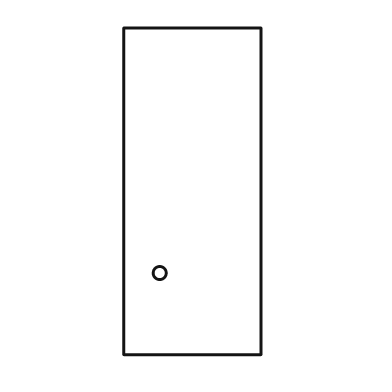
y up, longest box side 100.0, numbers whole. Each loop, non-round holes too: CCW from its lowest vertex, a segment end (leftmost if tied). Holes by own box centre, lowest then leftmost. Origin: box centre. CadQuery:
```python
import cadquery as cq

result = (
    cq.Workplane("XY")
    .moveTo(-21.0, -50.0)
    .lineTo(21.0, -50.0)
    .lineTo(21.0, 50.0)
    .lineTo(-21.0, 50.0)
    .close()
    .moveTo(-10.0, -25.0)
    .circle(2.0)
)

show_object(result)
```